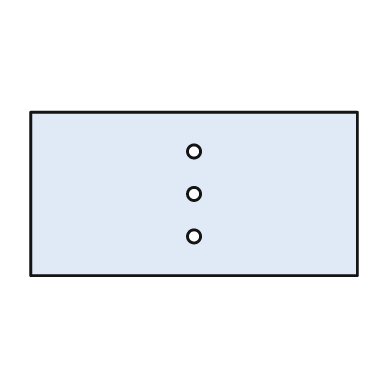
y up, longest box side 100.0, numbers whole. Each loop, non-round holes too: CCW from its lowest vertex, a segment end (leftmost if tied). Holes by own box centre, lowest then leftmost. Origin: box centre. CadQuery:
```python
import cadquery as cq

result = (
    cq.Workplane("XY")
    .moveTo(-50.0, -25.0)
    .lineTo(50.0, -25.0)
    .lineTo(50.0, 25.0)
    .lineTo(-50.0, 25.0)
    .close()
    .moveTo(0.0, -13.0)
    .circle(2.0)
    .moveTo(0.0, 0.0)
    .circle(2.0)
    .moveTo(0.0, 13.0)
    .circle(2.0)
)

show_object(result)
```